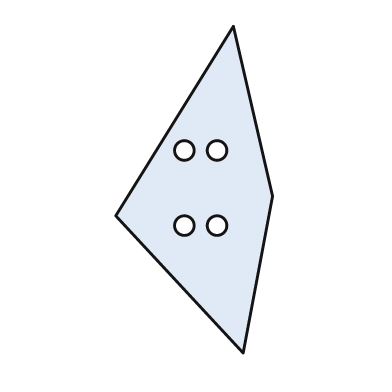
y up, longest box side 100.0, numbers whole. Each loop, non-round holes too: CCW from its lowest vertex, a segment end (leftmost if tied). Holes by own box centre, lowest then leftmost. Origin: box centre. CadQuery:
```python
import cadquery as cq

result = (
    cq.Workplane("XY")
    .moveTo(15.0, -50.0)
    .lineTo(24.0, -2.0)
    .lineTo(12.0, 50.0)
    .lineTo(-24.0, -8.0)
    .close()
    .moveTo(-3.0, -11.0)
    .circle(3.0)
    .moveTo(7.0, -11.0)
    .circle(3.0)
    .moveTo(-3.0, 12.0)
    .circle(3.0)
    .moveTo(7.0, 12.0)
    .circle(3.0)
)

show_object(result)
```